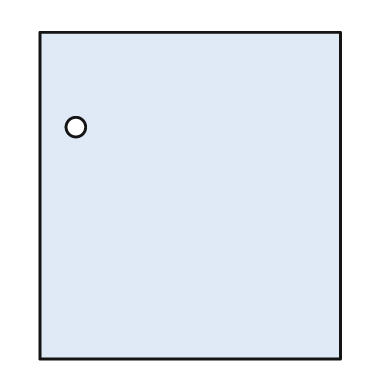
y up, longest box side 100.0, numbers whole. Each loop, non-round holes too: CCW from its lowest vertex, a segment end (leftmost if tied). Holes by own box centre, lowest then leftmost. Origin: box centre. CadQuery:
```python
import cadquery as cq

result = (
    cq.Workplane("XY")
    .moveTo(-46.0, -50.0)
    .lineTo(46.0, -50.0)
    .lineTo(46.0, 50.0)
    .lineTo(-46.0, 50.0)
    .close()
    .moveTo(-35.0, 21.0)
    .circle(3.0)
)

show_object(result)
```